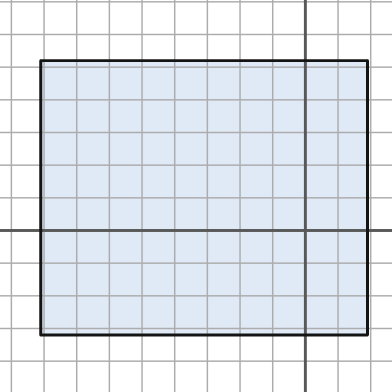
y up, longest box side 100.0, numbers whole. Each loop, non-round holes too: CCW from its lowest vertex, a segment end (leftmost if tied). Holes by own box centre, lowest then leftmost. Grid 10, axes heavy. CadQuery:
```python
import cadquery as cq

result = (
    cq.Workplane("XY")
    .moveTo(-81.0, -32.0)
    .lineTo(19.0, -32.0)
    .lineTo(19.0, 52.0)
    .lineTo(-81.0, 52.0)
    .close()
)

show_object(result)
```